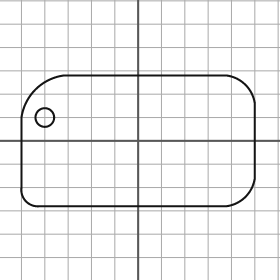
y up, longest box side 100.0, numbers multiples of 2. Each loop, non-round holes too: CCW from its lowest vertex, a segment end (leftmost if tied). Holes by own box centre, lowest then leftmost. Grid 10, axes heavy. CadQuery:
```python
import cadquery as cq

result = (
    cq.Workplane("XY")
    .moveTo(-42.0, -28.0)
    .lineTo(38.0, -28.0)
    .threePointArc((46.0, -24.0), (50.0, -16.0))
    .lineTo(50.0, 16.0)
    .threePointArc((46.0, 24.0), (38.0, 28.0))
    .lineTo(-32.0, 28.0)
    .threePointArc((-44.0, 22.0), (-50.0, 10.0))
    .lineTo(-50.0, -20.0)
    .threePointArc((-48.0, -26.0), (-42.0, -28.0))
    .close()
    .moveTo(-40.0, 10.0)
    .circle(4.0)
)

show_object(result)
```